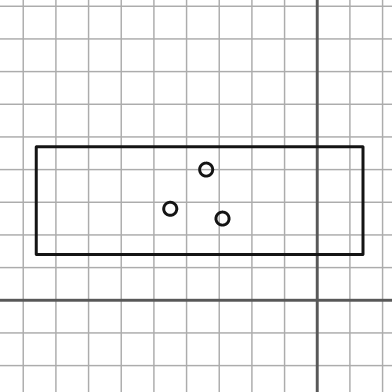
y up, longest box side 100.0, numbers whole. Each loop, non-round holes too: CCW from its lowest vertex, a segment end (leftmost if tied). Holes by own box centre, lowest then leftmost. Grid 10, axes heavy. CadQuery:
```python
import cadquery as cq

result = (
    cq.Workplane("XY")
    .moveTo(-86.0, 14.0)
    .lineTo(14.0, 14.0)
    .lineTo(14.0, 47.0)
    .lineTo(-86.0, 47.0)
    .close()
    .moveTo(-29.0, 25.0)
    .circle(2.0)
    .moveTo(-45.0, 28.0)
    .circle(2.0)
    .moveTo(-34.0, 40.0)
    .circle(2.0)
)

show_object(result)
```